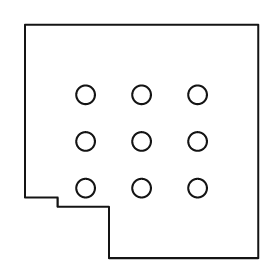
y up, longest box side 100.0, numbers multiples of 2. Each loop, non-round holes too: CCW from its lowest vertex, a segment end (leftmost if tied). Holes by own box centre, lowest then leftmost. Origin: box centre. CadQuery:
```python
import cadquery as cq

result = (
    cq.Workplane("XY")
    .moveTo(-14.0, -50.0)
    .lineTo(50.0, -50.0)
    .lineTo(50.0, 50.0)
    .lineTo(-50.0, 50.0)
    .lineTo(-50.0, -24.0)
    .lineTo(-36.0, -24.0)
    .lineTo(-36.0, -28.0)
    .lineTo(-14.0, -28.0)
    .close()
    .moveTo(-24.0, -20.0)
    .circle(4.0)
    .moveTo(0.0, -20.0)
    .circle(4.0)
    .moveTo(24.0, -20.0)
    .circle(4.0)
    .moveTo(-24.0, 0.0)
    .circle(4.0)
    .moveTo(0.0, 0.0)
    .circle(4.0)
    .moveTo(24.0, 0.0)
    .circle(4.0)
    .moveTo(-24.0, 20.0)
    .circle(4.0)
    .moveTo(0.0, 20.0)
    .circle(4.0)
    .moveTo(24.0, 20.0)
    .circle(4.0)
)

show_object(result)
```